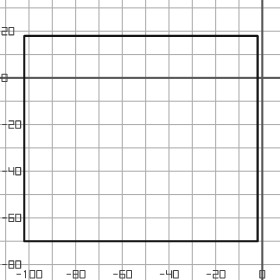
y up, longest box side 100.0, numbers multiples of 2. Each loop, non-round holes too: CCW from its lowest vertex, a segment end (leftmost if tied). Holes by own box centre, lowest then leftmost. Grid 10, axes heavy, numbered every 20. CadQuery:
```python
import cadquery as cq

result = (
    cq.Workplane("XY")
    .moveTo(-102.0, -70.0)
    .lineTo(-2.0, -70.0)
    .lineTo(-2.0, 18.0)
    .lineTo(-102.0, 18.0)
    .close()
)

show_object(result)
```